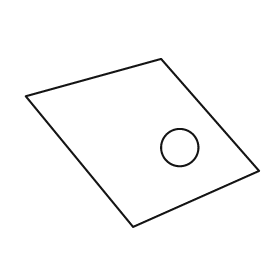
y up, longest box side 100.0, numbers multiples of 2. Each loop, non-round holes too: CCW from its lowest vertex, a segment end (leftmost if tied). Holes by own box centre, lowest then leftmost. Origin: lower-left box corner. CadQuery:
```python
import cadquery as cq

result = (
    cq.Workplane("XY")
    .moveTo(46.0, 0.0)
    .lineTo(100.0, 24.0)
    .lineTo(58.0, 72.0)
    .lineTo(0.0, 56.0)
    .close()
    .moveTo(66.0, 34.0)
    .circle(8.0)
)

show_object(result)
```